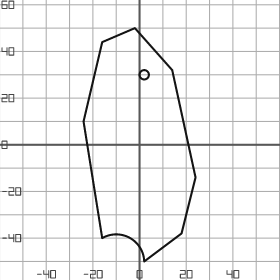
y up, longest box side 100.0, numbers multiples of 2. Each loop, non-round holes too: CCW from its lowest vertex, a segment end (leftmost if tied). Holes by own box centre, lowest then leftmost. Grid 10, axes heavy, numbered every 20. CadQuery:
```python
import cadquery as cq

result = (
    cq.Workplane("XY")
    .moveTo(2.0, -50.0)
    .lineTo(18.0, -38.0)
    .lineTo(24.0, -14.0)
    .lineTo(14.0, 32.0)
    .lineTo(-2.0, 50.0)
    .lineTo(-16.0, 44.0)
    .lineTo(-24.0, 10.0)
    .lineTo(-16.0, -40.0)
    .threePointArc((-4.0, -40.0), (2.0, -50.0))
    .close()
    .moveTo(2.0, 30.0)
    .circle(2.0)
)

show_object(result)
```